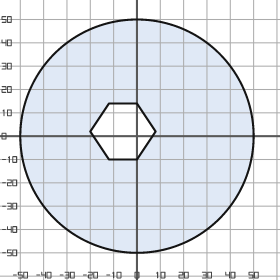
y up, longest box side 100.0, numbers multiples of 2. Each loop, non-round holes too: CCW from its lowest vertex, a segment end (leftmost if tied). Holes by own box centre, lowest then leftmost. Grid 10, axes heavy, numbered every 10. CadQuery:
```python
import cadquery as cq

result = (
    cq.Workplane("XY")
    .moveTo(0.0, 0.0)
    .circle(50.0)
    .moveTo(-12.0, -10.0)
    .lineTo(0.0, -10.0)
    .lineTo(8.0, 2.0)
    .lineTo(0.0, 14.0)
    .lineTo(-12.0, 14.0)
    .lineTo(-20.0, 2.0)
    .close()
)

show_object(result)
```